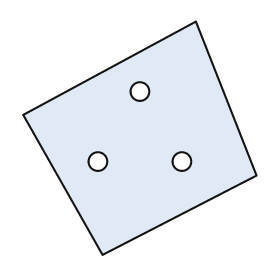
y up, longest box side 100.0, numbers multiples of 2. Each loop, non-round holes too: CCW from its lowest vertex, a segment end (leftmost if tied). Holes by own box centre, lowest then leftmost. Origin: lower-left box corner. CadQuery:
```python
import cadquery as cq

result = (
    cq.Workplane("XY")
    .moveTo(34.0, 0.0)
    .lineTo(100.0, 34.0)
    .lineTo(74.0, 100.0)
    .lineTo(0.0, 60.0)
    .close()
    .moveTo(32.0, 40.0)
    .circle(4.0)
    .moveTo(68.0, 40.0)
    .circle(4.0)
    .moveTo(50.0, 70.0)
    .circle(4.0)
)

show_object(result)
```